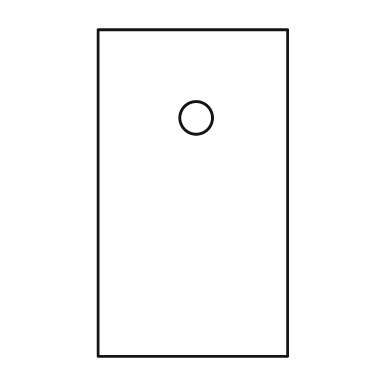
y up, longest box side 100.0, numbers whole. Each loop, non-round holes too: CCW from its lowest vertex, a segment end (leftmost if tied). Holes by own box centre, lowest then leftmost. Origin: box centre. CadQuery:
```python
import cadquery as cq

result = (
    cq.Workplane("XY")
    .moveTo(-29.0, -50.0)
    .lineTo(29.0, -50.0)
    .lineTo(29.0, 50.0)
    .lineTo(-29.0, 50.0)
    .close()
    .moveTo(1.0, 23.0)
    .circle(5.0)
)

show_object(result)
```